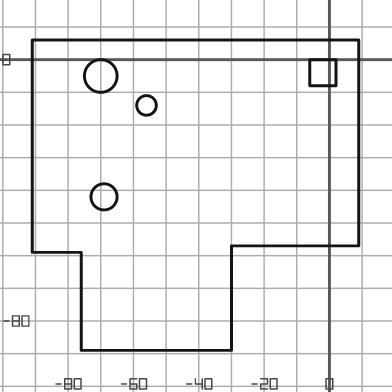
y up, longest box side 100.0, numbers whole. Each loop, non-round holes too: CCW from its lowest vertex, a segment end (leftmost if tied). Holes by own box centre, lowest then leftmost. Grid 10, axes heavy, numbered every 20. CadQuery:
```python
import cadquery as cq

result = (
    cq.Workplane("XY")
    .moveTo(-76.0, -89.0)
    .lineTo(-30.0, -89.0)
    .lineTo(-30.0, -57.0)
    .lineTo(9.0, -57.0)
    .lineTo(9.0, 6.0)
    .lineTo(-91.0, 6.0)
    .lineTo(-91.0, -59.0)
    .lineTo(-76.0, -59.0)
    .close()
    .moveTo(-69.0, -42.0)
    .circle(4.0)
    .moveTo(-56.0, -14.0)
    .circle(3.0)
    .moveTo(-70.0, -5.0)
    .circle(5.0)
    .moveTo(-6.0, -8.0)
    .lineTo(2.0, -8.0)
    .lineTo(2.0, 0.0)
    .lineTo(-6.0, 0.0)
    .close()
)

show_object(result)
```